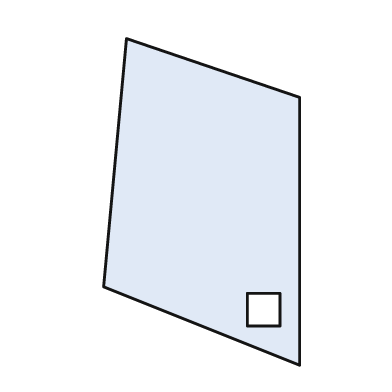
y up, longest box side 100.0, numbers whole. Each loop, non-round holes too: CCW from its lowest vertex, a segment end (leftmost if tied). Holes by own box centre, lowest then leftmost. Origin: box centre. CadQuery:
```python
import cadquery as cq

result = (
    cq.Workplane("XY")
    .moveTo(30.0, -50.0)
    .lineTo(30.0, 32.0)
    .lineTo(-23.0, 50.0)
    .lineTo(-30.0, -26.0)
    .close()
    .moveTo(14.0, -38.0)
    .lineTo(24.0, -38.0)
    .lineTo(24.0, -28.0)
    .lineTo(14.0, -28.0)
    .close()
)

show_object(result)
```